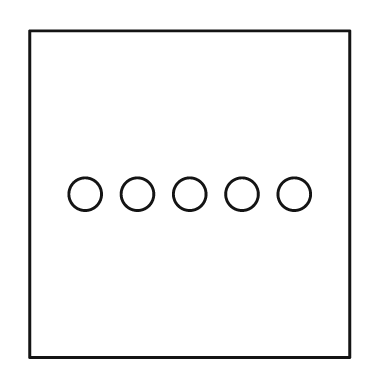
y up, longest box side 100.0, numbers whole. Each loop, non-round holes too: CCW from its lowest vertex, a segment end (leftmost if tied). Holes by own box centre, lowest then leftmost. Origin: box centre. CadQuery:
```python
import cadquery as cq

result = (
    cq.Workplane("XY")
    .moveTo(-49.0, -50.0)
    .lineTo(49.0, -50.0)
    .lineTo(49.0, 50.0)
    .lineTo(-49.0, 50.0)
    .close()
    .moveTo(-32.0, 0.0)
    .circle(5.0)
    .moveTo(-16.0, 0.0)
    .circle(5.0)
    .moveTo(0.0, 0.0)
    .circle(5.0)
    .moveTo(16.0, 0.0)
    .circle(5.0)
    .moveTo(32.0, 0.0)
    .circle(5.0)
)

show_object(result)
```